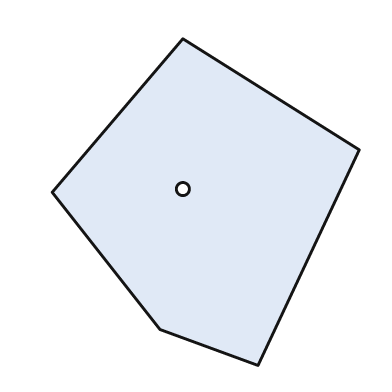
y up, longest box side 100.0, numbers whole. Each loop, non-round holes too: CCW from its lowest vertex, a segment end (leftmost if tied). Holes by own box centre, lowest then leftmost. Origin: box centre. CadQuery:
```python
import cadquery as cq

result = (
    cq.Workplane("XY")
    .moveTo(16.0, -50.0)
    .lineTo(47.0, 16.0)
    .lineTo(-7.0, 50.0)
    .lineTo(-47.0, 3.0)
    .lineTo(-14.0, -39.0)
    .close()
    .moveTo(-7.0, 4.0)
    .circle(2.0)
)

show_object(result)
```